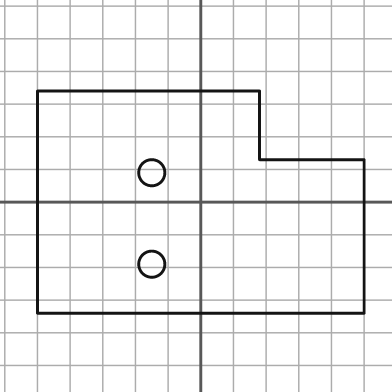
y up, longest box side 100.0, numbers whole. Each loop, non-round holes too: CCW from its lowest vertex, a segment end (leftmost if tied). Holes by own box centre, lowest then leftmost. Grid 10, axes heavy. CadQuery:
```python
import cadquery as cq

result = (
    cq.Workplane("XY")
    .moveTo(-50.0, -34.0)
    .lineTo(50.0, -34.0)
    .lineTo(50.0, 13.0)
    .lineTo(18.0, 13.0)
    .lineTo(18.0, 34.0)
    .lineTo(-50.0, 34.0)
    .close()
    .moveTo(-15.0, -19.0)
    .circle(4.0)
    .moveTo(-15.0, 9.0)
    .circle(4.0)
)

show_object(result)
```